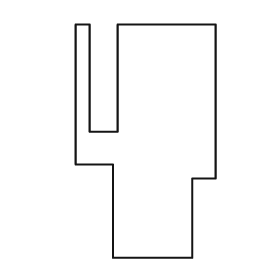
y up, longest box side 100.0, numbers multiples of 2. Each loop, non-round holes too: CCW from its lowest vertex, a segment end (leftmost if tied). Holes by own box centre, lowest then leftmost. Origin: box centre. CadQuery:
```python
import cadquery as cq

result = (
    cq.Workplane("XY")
    .moveTo(-14.0, -50.0)
    .lineTo(20.0, -50.0)
    .lineTo(20.0, -16.0)
    .lineTo(30.0, -16.0)
    .lineTo(30.0, 50.0)
    .lineTo(-12.0, 50.0)
    .lineTo(-12.0, 4.0)
    .lineTo(-24.0, 4.0)
    .lineTo(-24.0, 50.0)
    .lineTo(-30.0, 50.0)
    .lineTo(-30.0, -10.0)
    .lineTo(-14.0, -10.0)
    .close()
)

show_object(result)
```